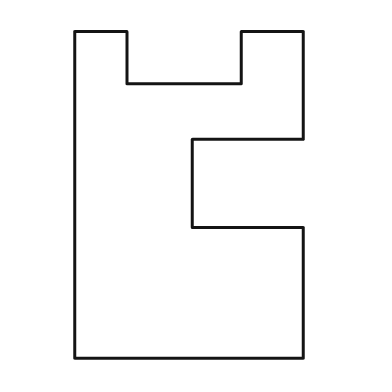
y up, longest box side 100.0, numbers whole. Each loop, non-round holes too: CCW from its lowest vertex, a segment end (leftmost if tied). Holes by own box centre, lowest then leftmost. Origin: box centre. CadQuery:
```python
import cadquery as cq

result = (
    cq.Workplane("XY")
    .moveTo(-35.0, -50.0)
    .lineTo(35.0, -50.0)
    .lineTo(35.0, -10.0)
    .lineTo(1.0, -10.0)
    .lineTo(1.0, 17.0)
    .lineTo(35.0, 17.0)
    .lineTo(35.0, 50.0)
    .lineTo(16.0, 50.0)
    .lineTo(16.0, 34.0)
    .lineTo(-19.0, 34.0)
    .lineTo(-19.0, 50.0)
    .lineTo(-35.0, 50.0)
    .close()
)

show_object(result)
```